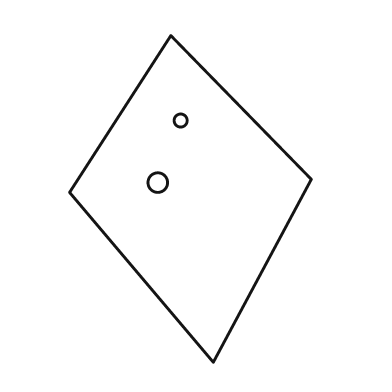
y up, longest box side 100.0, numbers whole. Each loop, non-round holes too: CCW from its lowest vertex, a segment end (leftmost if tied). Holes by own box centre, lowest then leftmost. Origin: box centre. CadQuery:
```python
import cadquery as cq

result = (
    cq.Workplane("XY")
    .moveTo(7.0, -50.0)
    .lineTo(37.0, 6.0)
    .lineTo(-6.0, 50.0)
    .lineTo(-37.0, 2.0)
    .close()
    .moveTo(-10.0, 5.0)
    .circle(3.0)
    .moveTo(-3.0, 24.0)
    .circle(2.0)
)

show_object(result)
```